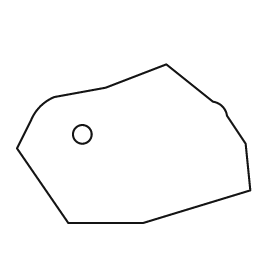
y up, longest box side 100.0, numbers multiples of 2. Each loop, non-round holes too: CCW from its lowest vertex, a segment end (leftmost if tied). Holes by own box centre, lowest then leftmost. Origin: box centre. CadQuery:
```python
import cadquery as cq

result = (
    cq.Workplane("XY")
    .moveTo(-28.0, -34.0)
    .lineTo(4.0, -34.0)
    .lineTo(50.0, -20.0)
    .lineTo(48.0, 0.0)
    .lineTo(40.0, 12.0)
    .threePointArc((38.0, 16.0), (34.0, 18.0))
    .lineTo(14.0, 34.0)
    .lineTo(-12.0, 24.0)
    .lineTo(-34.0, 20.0)
    .threePointArc((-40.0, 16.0), (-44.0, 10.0))
    .lineTo(-50.0, -2.0)
    .close()
    .moveTo(-22.0, 4.0)
    .circle(4.0)
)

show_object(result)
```